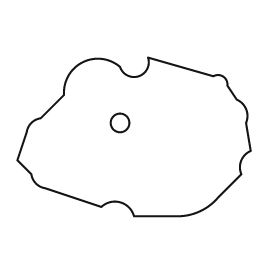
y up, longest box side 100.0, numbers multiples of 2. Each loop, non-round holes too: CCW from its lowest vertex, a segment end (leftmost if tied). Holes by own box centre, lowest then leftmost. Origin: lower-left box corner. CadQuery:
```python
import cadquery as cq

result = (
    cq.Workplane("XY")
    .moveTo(50.0, 0.0)
    .lineTo(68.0, 0.0)
    .threePointArc((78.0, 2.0), (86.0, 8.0))
    .lineTo(96.0, 18.0)
    .threePointArc((96.0, 24.0), (100.0, 28.0))
    .lineTo(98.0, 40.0)
    .threePointArc((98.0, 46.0), (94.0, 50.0))
    .lineTo(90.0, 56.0)
    .threePointArc((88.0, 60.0), (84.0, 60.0))
    .lineTo(56.0, 68.0)
    .threePointArc((52.0, 60.0), (44.0, 64.0))
    .threePointArc((28.0, 66.0), (20.0, 52.0))
    .lineTo(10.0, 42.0)
    .threePointArc((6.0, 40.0), (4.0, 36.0))
    .lineTo(0.0, 24.0)
    .lineTo(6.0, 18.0)
    .threePointArc((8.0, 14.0), (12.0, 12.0))
    .lineTo(36.0, 4.0)
    .threePointArc((44.0, 6.0), (50.0, 0.0))
    .close()
    .moveTo(44.0, 40.0)
    .circle(4.0)
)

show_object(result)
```